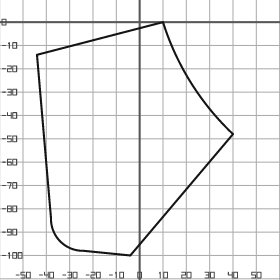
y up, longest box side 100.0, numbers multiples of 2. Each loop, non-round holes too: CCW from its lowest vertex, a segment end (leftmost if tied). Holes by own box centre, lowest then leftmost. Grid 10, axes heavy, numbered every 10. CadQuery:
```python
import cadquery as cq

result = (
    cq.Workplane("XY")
    .moveTo(-4.0, -100.0)
    .lineTo(40.0, -48.0)
    .threePointArc((22.0, -26.0), (10.0, 0.0))
    .lineTo(-44.0, -14.0)
    .lineTo(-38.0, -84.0)
    .threePointArc((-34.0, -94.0), (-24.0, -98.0))
    .close()
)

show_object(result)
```